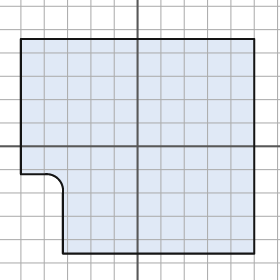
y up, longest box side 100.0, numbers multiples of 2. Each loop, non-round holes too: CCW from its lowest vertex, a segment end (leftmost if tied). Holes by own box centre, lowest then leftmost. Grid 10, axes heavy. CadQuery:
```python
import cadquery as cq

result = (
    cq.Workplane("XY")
    .moveTo(-32.0, -46.0)
    .lineTo(50.0, -46.0)
    .lineTo(50.0, 46.0)
    .lineTo(-50.0, 46.0)
    .lineTo(-50.0, -12.0)
    .lineTo(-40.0, -12.0)
    .threePointArc((-34.0, -14.0), (-32.0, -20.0))
    .close()
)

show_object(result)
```